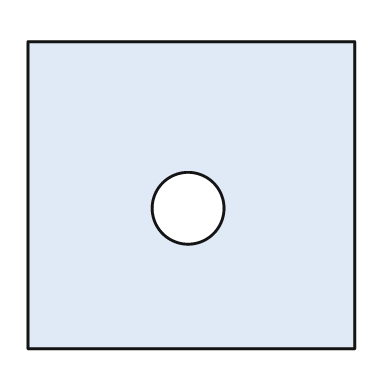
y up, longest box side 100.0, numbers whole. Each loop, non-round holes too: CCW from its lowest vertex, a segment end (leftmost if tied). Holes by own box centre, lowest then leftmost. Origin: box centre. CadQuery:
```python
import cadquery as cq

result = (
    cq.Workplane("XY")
    .moveTo(-50.0, -47.0)
    .lineTo(50.0, -47.0)
    .lineTo(50.0, 47.0)
    .lineTo(-50.0, 47.0)
    .close()
    .moveTo(-1.0, -4.0)
    .circle(11.0)
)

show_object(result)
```